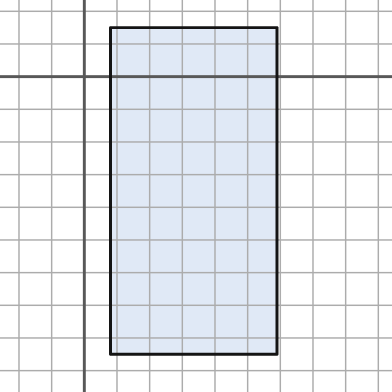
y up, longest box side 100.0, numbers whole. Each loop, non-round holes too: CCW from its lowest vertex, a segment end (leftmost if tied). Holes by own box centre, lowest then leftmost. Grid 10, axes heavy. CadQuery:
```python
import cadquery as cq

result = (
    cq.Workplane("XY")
    .moveTo(8.0, -85.0)
    .lineTo(59.0, -85.0)
    .lineTo(59.0, 15.0)
    .lineTo(8.0, 15.0)
    .close()
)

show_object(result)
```